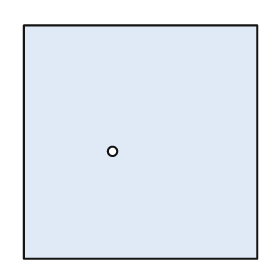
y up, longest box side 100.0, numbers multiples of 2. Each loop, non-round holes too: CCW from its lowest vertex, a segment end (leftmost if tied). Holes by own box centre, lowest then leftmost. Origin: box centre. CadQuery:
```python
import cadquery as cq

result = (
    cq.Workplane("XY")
    .moveTo(-50.0, -50.0)
    .lineTo(50.0, -50.0)
    .lineTo(50.0, 50.0)
    .lineTo(-50.0, 50.0)
    .close()
    .moveTo(-12.0, -4.0)
    .circle(2.0)
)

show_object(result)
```